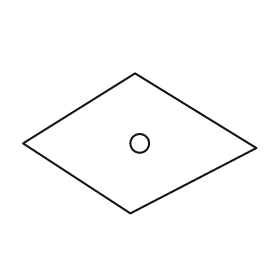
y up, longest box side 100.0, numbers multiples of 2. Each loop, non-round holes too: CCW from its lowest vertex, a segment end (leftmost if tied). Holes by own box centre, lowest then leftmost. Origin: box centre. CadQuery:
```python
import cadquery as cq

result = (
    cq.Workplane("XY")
    .moveTo(-4.0, -30.0)
    .lineTo(50.0, -2.0)
    .lineTo(-2.0, 30.0)
    .lineTo(-50.0, 0.0)
    .close()
    .moveTo(0.0, 0.0)
    .circle(4.0)
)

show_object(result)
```